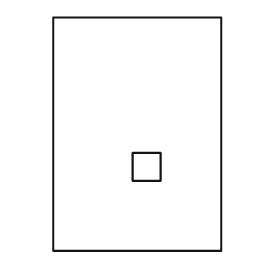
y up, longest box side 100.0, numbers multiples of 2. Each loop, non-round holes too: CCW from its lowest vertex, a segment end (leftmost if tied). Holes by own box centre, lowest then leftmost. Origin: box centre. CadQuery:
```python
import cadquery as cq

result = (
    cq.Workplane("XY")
    .moveTo(-36.0, -50.0)
    .lineTo(36.0, -50.0)
    .lineTo(36.0, 50.0)
    .lineTo(-36.0, 50.0)
    .close()
    .moveTo(-2.0, -20.0)
    .lineTo(10.0, -20.0)
    .lineTo(10.0, -8.0)
    .lineTo(-2.0, -8.0)
    .close()
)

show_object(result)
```